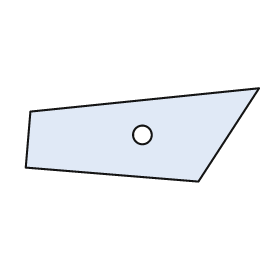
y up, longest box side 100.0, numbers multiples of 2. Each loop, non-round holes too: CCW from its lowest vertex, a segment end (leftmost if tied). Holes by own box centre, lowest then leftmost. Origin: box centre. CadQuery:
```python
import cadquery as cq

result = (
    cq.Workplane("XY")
    .moveTo(24.0, -20.0)
    .lineTo(50.0, 20.0)
    .lineTo(-48.0, 10.0)
    .lineTo(-50.0, -14.0)
    .close()
    .moveTo(0.0, 0.0)
    .circle(4.0)
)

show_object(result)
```